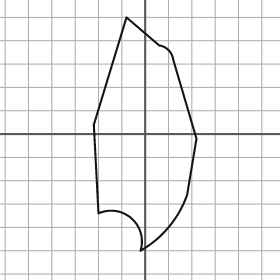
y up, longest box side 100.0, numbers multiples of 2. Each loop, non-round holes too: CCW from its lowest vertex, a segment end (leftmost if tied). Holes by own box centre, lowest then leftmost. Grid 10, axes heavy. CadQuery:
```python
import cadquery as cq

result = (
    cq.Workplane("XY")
    .moveTo(-2.0, -50.0)
    .threePointArc((10.0, -40.0), (18.0, -26.0))
    .lineTo(22.0, -2.0)
    .lineTo(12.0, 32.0)
    .threePointArc((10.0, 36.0), (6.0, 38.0))
    .lineTo(-8.0, 50.0)
    .lineTo(-22.0, 4.0)
    .lineTo(-20.0, -34.0)
    .threePointArc((-6.0, -36.0), (-2.0, -50.0))
    .close()
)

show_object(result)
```